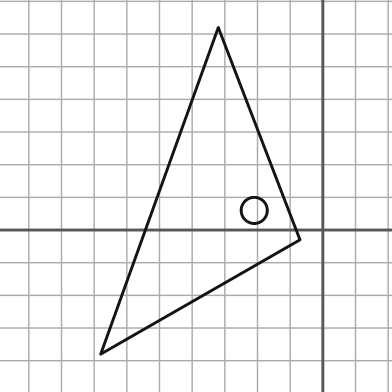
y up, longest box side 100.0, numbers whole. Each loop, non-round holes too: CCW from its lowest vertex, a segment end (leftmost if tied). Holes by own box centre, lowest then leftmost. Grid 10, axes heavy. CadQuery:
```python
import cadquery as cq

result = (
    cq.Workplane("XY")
    .moveTo(-68.0, -38.0)
    .lineTo(-7.0, -3.0)
    .lineTo(-32.0, 62.0)
    .close()
    .moveTo(-21.0, 6.0)
    .circle(4.0)
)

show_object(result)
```